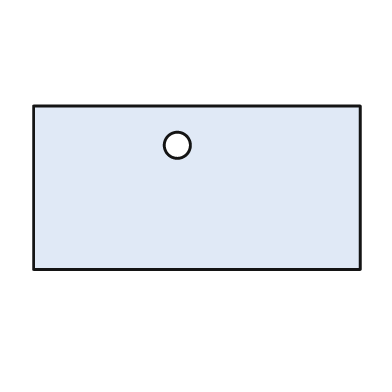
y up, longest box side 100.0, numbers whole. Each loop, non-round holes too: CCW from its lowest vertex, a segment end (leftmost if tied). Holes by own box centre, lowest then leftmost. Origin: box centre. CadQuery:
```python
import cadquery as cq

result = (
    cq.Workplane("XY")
    .moveTo(-50.0, -25.0)
    .lineTo(50.0, -25.0)
    .lineTo(50.0, 25.0)
    .lineTo(-50.0, 25.0)
    .close()
    .moveTo(-6.0, 13.0)
    .circle(4.0)
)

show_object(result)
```